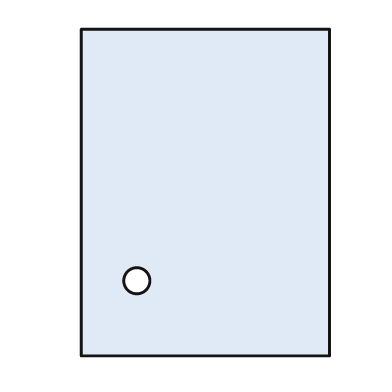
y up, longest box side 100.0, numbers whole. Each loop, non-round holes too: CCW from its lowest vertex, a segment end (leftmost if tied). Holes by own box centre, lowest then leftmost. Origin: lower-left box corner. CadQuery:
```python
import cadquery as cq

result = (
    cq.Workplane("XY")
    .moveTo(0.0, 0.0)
    .lineTo(76.0, 0.0)
    .lineTo(76.0, 100.0)
    .lineTo(0.0, 100.0)
    .close()
    .moveTo(17.0, 23.0)
    .circle(4.0)
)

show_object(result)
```